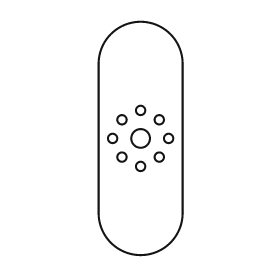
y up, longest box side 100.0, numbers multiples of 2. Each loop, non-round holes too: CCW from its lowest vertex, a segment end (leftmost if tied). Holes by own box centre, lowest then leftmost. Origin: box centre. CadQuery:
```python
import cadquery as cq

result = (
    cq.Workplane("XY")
    .moveTo(-18.0, -32.0)
    .threePointArc((0.0, -50.0), (18.0, -32.0))
    .lineTo(18.0, 32.0)
    .threePointArc((0.0, 50.0), (-18.0, 32.0))
    .close()
    .moveTo(0.0, -12.0)
    .circle(2.0)
    .moveTo(-8.0, -8.0)
    .circle(2.0)
    .moveTo(8.0, -8.0)
    .circle(2.0)
    .moveTo(-12.0, 0.0)
    .circle(2.0)
    .moveTo(0.0, 0.0)
    .circle(4.0)
    .moveTo(12.0, 0.0)
    .circle(2.0)
    .moveTo(-8.0, 8.0)
    .circle(2.0)
    .moveTo(8.0, 8.0)
    .circle(2.0)
    .moveTo(0.0, 12.0)
    .circle(2.0)
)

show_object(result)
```